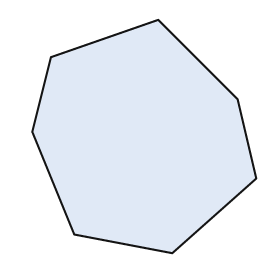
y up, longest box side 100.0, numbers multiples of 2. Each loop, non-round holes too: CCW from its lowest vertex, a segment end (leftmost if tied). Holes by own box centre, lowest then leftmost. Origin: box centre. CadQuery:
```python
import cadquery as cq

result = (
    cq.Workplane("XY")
    .moveTo(12.0, -50.0)
    .lineTo(48.0, -18.0)
    .lineTo(40.0, 16.0)
    .lineTo(6.0, 50.0)
    .lineTo(-40.0, 34.0)
    .lineTo(-48.0, 2.0)
    .lineTo(-30.0, -42.0)
    .close()
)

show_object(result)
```